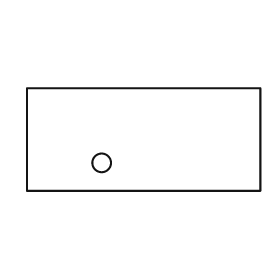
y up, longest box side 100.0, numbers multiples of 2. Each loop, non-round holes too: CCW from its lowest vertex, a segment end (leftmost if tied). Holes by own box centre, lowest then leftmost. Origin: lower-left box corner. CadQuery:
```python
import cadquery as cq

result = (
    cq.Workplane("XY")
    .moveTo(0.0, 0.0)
    .lineTo(100.0, 0.0)
    .lineTo(100.0, 44.0)
    .lineTo(0.0, 44.0)
    .close()
    .moveTo(32.0, 12.0)
    .circle(4.0)
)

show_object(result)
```